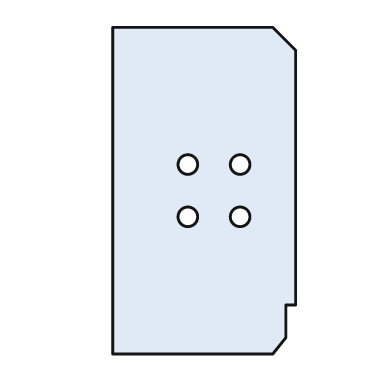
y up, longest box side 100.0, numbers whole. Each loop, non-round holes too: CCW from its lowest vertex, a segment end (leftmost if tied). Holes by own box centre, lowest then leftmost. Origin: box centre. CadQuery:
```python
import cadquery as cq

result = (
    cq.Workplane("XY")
    .moveTo(-28.0, -50.0)
    .lineTo(21.0, -50.0)
    .lineTo(25.0, -45.0)
    .lineTo(25.0, -35.0)
    .lineTo(28.0, -35.0)
    .lineTo(28.0, 43.0)
    .lineTo(21.0, 50.0)
    .lineTo(-28.0, 50.0)
    .close()
    .moveTo(-5.0, -8.0)
    .circle(3.0)
    .moveTo(11.0, -8.0)
    .circle(3.0)
    .moveTo(-5.0, 8.0)
    .circle(3.0)
    .moveTo(11.0, 8.0)
    .circle(3.0)
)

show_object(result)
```